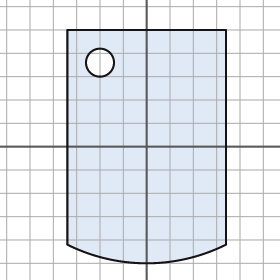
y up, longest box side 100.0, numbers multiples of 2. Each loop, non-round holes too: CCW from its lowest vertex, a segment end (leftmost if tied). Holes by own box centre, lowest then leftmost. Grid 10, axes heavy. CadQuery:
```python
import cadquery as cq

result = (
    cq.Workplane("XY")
    .moveTo(-34.0, -42.0)
    .threePointArc((0.0, -50.0), (34.0, -42.0))
    .lineTo(34.0, 50.0)
    .lineTo(-34.0, 50.0)
    .close()
    .moveTo(-20.0, 36.0)
    .circle(6.0)
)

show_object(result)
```